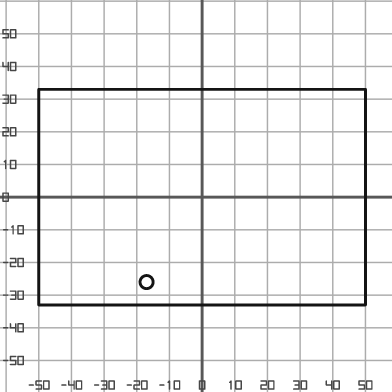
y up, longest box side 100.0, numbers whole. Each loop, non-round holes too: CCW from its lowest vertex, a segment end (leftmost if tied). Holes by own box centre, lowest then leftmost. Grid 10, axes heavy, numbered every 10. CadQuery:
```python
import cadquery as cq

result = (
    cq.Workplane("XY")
    .moveTo(-50.0, -33.0)
    .lineTo(50.0, -33.0)
    .lineTo(50.0, 33.0)
    .lineTo(-50.0, 33.0)
    .close()
    .moveTo(-17.0, -26.0)
    .circle(2.0)
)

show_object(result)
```